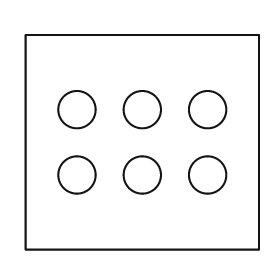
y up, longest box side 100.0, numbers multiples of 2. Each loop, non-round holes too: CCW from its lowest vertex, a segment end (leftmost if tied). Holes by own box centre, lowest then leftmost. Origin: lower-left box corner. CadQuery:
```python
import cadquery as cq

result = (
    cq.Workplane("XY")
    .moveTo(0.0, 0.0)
    .lineTo(100.0, 0.0)
    .lineTo(100.0, 92.0)
    .lineTo(0.0, 92.0)
    .close()
    .moveTo(22.0, 32.0)
    .circle(8.0)
    .moveTo(50.0, 32.0)
    .circle(8.0)
    .moveTo(78.0, 32.0)
    .circle(8.0)
    .moveTo(22.0, 60.0)
    .circle(8.0)
    .moveTo(50.0, 60.0)
    .circle(8.0)
    .moveTo(78.0, 60.0)
    .circle(8.0)
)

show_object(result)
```